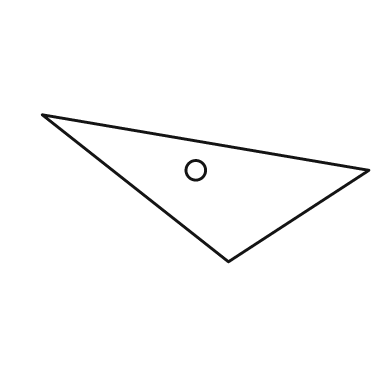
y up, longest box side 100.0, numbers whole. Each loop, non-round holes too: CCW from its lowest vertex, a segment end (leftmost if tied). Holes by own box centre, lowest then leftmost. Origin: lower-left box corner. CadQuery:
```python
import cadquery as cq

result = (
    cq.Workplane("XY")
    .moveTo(57.0, 0.0)
    .lineTo(100.0, 28.0)
    .lineTo(0.0, 45.0)
    .close()
    .moveTo(47.0, 28.0)
    .circle(3.0)
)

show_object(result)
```